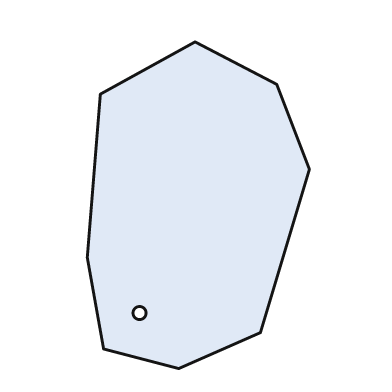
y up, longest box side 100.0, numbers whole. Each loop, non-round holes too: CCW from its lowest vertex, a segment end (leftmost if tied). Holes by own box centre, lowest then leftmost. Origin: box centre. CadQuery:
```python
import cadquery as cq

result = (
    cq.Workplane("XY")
    .moveTo(-6.0, -50.0)
    .lineTo(19.0, -39.0)
    .lineTo(34.0, 11.0)
    .lineTo(24.0, 37.0)
    .lineTo(-1.0, 50.0)
    .lineTo(-30.0, 34.0)
    .lineTo(-34.0, -16.0)
    .lineTo(-29.0, -44.0)
    .close()
    .moveTo(-18.0, -33.0)
    .circle(2.0)
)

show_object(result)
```